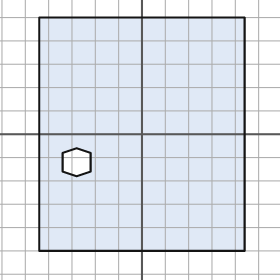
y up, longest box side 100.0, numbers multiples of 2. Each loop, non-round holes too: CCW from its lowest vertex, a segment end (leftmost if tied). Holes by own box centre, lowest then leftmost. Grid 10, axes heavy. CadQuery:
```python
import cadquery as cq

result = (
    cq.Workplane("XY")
    .moveTo(-44.0, -50.0)
    .lineTo(44.0, -50.0)
    .lineTo(44.0, 50.0)
    .lineTo(-44.0, 50.0)
    .close()
    .moveTo(-28.0, -18.0)
    .lineTo(-22.0, -16.0)
    .lineTo(-22.0, -8.0)
    .lineTo(-28.0, -6.0)
    .lineTo(-34.0, -8.0)
    .lineTo(-34.0, -16.0)
    .close()
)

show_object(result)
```